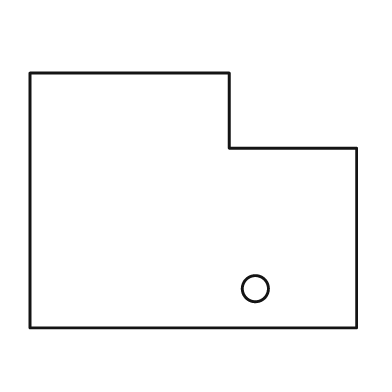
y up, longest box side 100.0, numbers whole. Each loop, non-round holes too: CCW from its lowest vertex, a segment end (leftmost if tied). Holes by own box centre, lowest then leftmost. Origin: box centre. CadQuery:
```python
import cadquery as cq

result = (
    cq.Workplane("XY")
    .moveTo(-50.0, -39.0)
    .lineTo(50.0, -39.0)
    .lineTo(50.0, 16.0)
    .lineTo(11.0, 16.0)
    .lineTo(11.0, 39.0)
    .lineTo(-50.0, 39.0)
    .close()
    .moveTo(19.0, -27.0)
    .circle(4.0)
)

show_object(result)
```